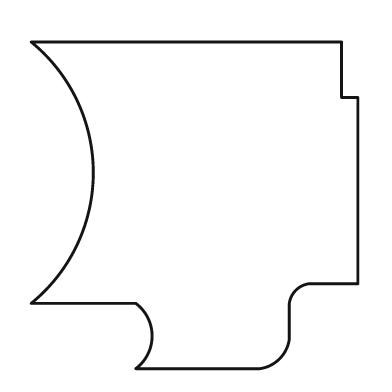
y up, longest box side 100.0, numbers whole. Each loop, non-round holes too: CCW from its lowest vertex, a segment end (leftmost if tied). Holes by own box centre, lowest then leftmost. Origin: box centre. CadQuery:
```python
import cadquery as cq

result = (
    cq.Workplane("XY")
    .moveTo(-18.0, -50.0)
    .lineTo(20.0, -50.0)
    .threePointArc((26.0, -47.0), (29.0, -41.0))
    .lineTo(29.0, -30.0)
    .threePointArc((31.0, -26.0), (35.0, -24.0))
    .lineTo(50.0, -24.0)
    .lineTo(50.0, 33.0)
    .lineTo(45.0, 33.0)
    .lineTo(45.0, 50.0)
    .lineTo(-50.0, 50.0)
    .threePointArc((-31.0, 10.0), (-50.0, -30.0))
    .lineTo(-18.0, -30.0)
    .threePointArc((-13.0, -40.0), (-18.0, -50.0))
    .close()
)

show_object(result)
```